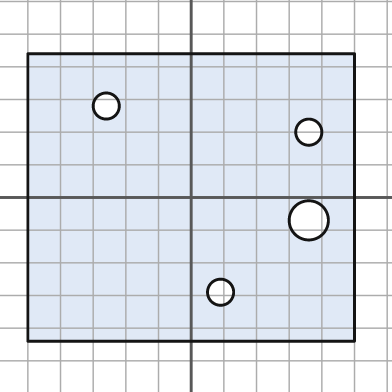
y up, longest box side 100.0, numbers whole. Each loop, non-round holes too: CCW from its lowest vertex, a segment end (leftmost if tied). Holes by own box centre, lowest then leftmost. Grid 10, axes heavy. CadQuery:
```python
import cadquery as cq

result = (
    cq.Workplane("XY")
    .moveTo(-50.0, -44.0)
    .lineTo(50.0, -44.0)
    .lineTo(50.0, 44.0)
    .lineTo(-50.0, 44.0)
    .close()
    .moveTo(9.0, -29.0)
    .circle(4.0)
    .moveTo(36.0, -7.0)
    .circle(6.0)
    .moveTo(36.0, 20.0)
    .circle(4.0)
    .moveTo(-26.0, 28.0)
    .circle(4.0)
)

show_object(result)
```